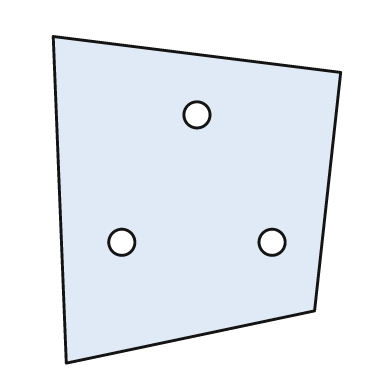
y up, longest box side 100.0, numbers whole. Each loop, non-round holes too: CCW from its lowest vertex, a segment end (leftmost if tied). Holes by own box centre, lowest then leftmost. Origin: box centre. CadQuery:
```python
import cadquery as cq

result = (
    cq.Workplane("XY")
    .moveTo(-40.0, -50.0)
    .lineTo(36.0, -34.0)
    .lineTo(44.0, 39.0)
    .lineTo(-44.0, 50.0)
    .close()
    .moveTo(-23.0, -13.0)
    .circle(4.0)
    .moveTo(23.0, -13.0)
    .circle(4.0)
    .moveTo(0.0, 26.0)
    .circle(4.0)
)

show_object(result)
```